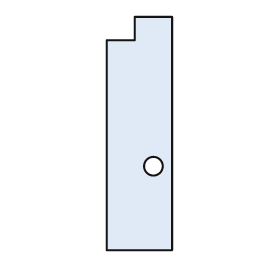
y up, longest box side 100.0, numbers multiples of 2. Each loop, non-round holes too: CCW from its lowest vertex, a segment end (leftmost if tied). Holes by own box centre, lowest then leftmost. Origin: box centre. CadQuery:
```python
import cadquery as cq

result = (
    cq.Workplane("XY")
    .moveTo(-14.0, -50.0)
    .lineTo(14.0, -50.0)
    .lineTo(14.0, 50.0)
    .lineTo(-2.0, 50.0)
    .lineTo(-2.0, 40.0)
    .lineTo(-14.0, 40.0)
    .close()
    .moveTo(6.0, -14.0)
    .circle(4.0)
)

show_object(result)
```